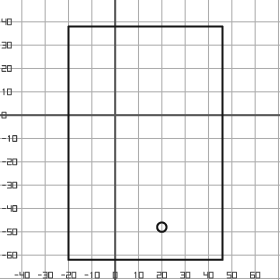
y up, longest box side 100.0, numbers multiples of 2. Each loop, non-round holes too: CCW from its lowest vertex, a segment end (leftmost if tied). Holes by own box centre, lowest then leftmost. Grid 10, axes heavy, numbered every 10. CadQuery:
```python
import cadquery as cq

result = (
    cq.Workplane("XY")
    .moveTo(-20.0, -62.0)
    .lineTo(46.0, -62.0)
    .lineTo(46.0, 38.0)
    .lineTo(-20.0, 38.0)
    .close()
    .moveTo(20.0, -48.0)
    .circle(2.0)
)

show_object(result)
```